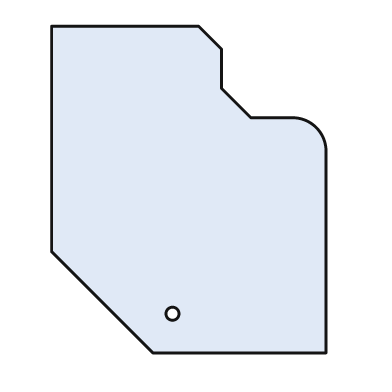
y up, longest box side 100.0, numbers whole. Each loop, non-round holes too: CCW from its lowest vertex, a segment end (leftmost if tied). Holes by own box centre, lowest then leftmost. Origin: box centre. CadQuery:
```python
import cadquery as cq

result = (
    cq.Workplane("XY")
    .moveTo(-11.0, -50.0)
    .lineTo(42.0, -50.0)
    .lineTo(42.0, 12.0)
    .threePointArc((39.0, 19.0), (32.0, 22.0))
    .lineTo(19.0, 22.0)
    .lineTo(10.0, 31.0)
    .lineTo(10.0, 43.0)
    .lineTo(3.0, 50.0)
    .lineTo(-42.0, 50.0)
    .lineTo(-42.0, -19.0)
    .close()
    .moveTo(-5.0, -38.0)
    .circle(2.0)
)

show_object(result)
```